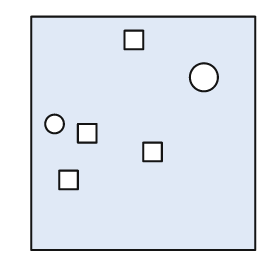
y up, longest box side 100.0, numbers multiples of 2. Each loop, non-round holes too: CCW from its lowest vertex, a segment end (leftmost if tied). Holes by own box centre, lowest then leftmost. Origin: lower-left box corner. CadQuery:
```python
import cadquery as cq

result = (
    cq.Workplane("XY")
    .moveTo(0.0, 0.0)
    .lineTo(96.0, 0.0)
    .lineTo(96.0, 100.0)
    .lineTo(0.0, 100.0)
    .close()
    .moveTo(12.0, 26.0)
    .lineTo(20.0, 26.0)
    .lineTo(20.0, 34.0)
    .lineTo(12.0, 34.0)
    .close()
    .moveTo(48.0, 38.0)
    .lineTo(56.0, 38.0)
    .lineTo(56.0, 46.0)
    .lineTo(48.0, 46.0)
    .close()
    .moveTo(20.0, 46.0)
    .lineTo(28.0, 46.0)
    .lineTo(28.0, 54.0)
    .lineTo(20.0, 54.0)
    .close()
    .moveTo(10.0, 54.0)
    .circle(4.0)
    .moveTo(74.0, 74.0)
    .circle(6.0)
    .moveTo(40.0, 86.0)
    .lineTo(48.0, 86.0)
    .lineTo(48.0, 94.0)
    .lineTo(40.0, 94.0)
    .close()
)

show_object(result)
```